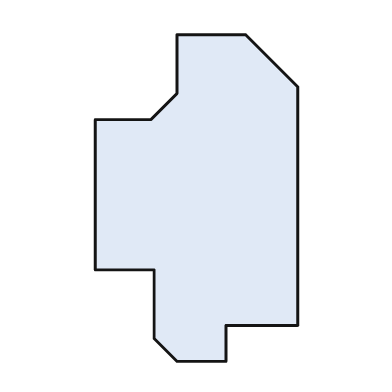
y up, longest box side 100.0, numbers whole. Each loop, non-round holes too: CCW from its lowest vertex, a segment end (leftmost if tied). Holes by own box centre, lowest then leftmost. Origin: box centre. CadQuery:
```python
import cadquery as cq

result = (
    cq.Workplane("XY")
    .moveTo(-6.0, -50.0)
    .lineTo(9.0, -50.0)
    .lineTo(9.0, -39.0)
    .lineTo(31.0, -39.0)
    .lineTo(31.0, 34.0)
    .lineTo(15.0, 50.0)
    .lineTo(-6.0, 50.0)
    .lineTo(-6.0, 32.0)
    .lineTo(-14.0, 24.0)
    .lineTo(-31.0, 24.0)
    .lineTo(-31.0, -22.0)
    .lineTo(-13.0, -22.0)
    .lineTo(-13.0, -43.0)
    .close()
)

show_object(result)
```